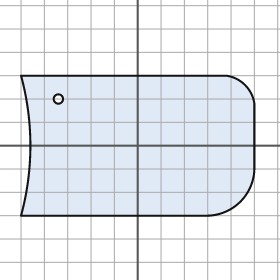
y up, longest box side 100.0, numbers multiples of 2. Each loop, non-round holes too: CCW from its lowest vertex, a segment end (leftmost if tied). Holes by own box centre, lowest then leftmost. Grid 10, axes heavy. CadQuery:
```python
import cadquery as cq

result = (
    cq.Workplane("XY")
    .moveTo(-50.0, -30.0)
    .lineTo(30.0, -30.0)
    .threePointArc((44.0, -24.0), (50.0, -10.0))
    .lineTo(50.0, 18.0)
    .threePointArc((46.0, 26.0), (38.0, 30.0))
    .lineTo(-50.0, 30.0)
    .threePointArc((-46.0, 0.0), (-50.0, -30.0))
    .close()
    .moveTo(-34.0, 20.0)
    .circle(2.0)
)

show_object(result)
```